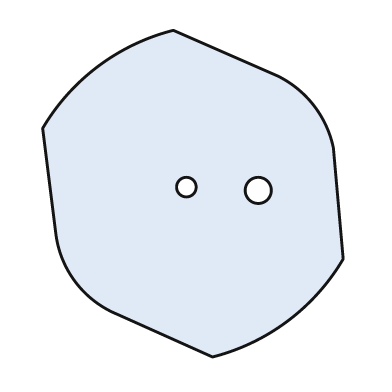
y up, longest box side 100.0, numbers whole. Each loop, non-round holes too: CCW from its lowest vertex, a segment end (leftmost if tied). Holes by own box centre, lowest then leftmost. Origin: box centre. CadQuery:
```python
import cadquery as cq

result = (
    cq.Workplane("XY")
    .moveTo(6.0, -50.0)
    .threePointArc((29.0, -39.0), (46.0, -20.0))
    .lineTo(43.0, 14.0)
    .threePointArc((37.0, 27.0), (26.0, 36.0))
    .lineTo(-6.0, 50.0)
    .threePointArc((-29.0, 39.0), (-46.0, 20.0))
    .lineTo(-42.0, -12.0)
    .threePointArc((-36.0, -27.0), (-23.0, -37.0))
    .close()
    .moveTo(20.0, 1.0)
    .circle(4.0)
    .moveTo(-2.0, 2.0)
    .circle(3.0)
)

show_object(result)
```